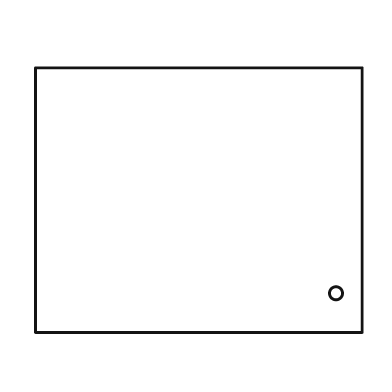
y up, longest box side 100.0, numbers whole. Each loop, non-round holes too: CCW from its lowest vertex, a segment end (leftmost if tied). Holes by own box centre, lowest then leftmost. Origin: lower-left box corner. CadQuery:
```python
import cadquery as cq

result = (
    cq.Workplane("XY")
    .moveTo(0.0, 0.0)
    .lineTo(100.0, 0.0)
    .lineTo(100.0, 81.0)
    .lineTo(0.0, 81.0)
    .close()
    .moveTo(92.0, 12.0)
    .circle(2.0)
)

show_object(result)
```